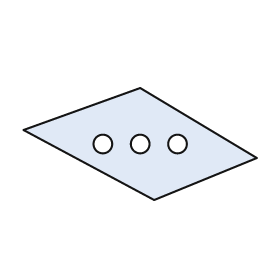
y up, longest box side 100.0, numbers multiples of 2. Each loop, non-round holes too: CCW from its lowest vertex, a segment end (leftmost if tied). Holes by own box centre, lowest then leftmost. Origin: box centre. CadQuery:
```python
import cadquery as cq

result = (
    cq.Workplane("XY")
    .moveTo(6.0, -24.0)
    .lineTo(50.0, -6.0)
    .lineTo(0.0, 24.0)
    .lineTo(-50.0, 6.0)
    .close()
    .moveTo(-16.0, 0.0)
    .circle(4.0)
    .moveTo(0.0, 0.0)
    .circle(4.0)
    .moveTo(16.0, 0.0)
    .circle(4.0)
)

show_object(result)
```